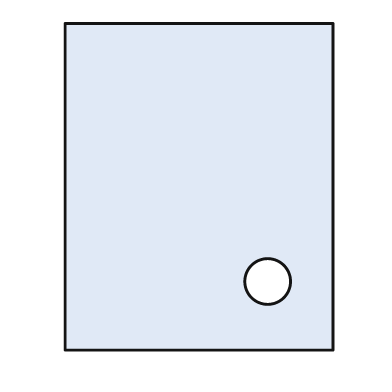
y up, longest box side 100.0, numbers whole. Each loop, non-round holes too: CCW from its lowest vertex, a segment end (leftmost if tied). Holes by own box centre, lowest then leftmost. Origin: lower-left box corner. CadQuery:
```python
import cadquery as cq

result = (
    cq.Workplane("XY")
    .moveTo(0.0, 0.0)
    .lineTo(82.0, 0.0)
    .lineTo(82.0, 100.0)
    .lineTo(0.0, 100.0)
    .close()
    .moveTo(62.0, 21.0)
    .circle(7.0)
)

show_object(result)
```